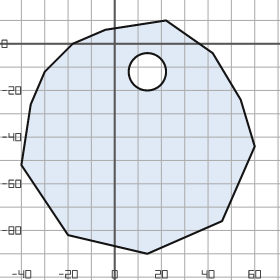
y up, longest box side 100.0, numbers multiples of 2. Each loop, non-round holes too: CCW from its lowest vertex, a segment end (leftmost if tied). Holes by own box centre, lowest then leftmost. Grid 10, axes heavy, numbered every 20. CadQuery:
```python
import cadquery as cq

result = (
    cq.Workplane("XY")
    .moveTo(14.0, -90.0)
    .lineTo(46.0, -76.0)
    .lineTo(60.0, -44.0)
    .lineTo(54.0, -24.0)
    .lineTo(42.0, -4.0)
    .lineTo(22.0, 10.0)
    .lineTo(-4.0, 6.0)
    .lineTo(-18.0, 0.0)
    .lineTo(-30.0, -12.0)
    .lineTo(-36.0, -26.0)
    .lineTo(-40.0, -52.0)
    .lineTo(-20.0, -82.0)
    .close()
    .moveTo(14.0, -12.0)
    .circle(8.0)
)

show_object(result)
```